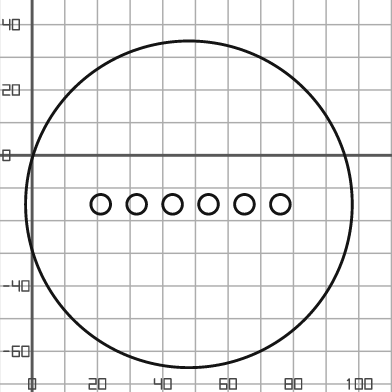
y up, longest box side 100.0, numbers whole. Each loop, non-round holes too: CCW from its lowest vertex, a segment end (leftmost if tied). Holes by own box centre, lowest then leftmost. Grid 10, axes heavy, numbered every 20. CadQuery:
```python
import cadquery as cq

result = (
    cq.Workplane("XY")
    .moveTo(48.0, -15.0)
    .circle(50.0)
    .moveTo(21.0, -15.0)
    .circle(3.0)
    .moveTo(32.0, -15.0)
    .circle(3.0)
    .moveTo(43.0, -15.0)
    .circle(3.0)
    .moveTo(54.0, -15.0)
    .circle(3.0)
    .moveTo(65.0, -15.0)
    .circle(3.0)
    .moveTo(76.0, -15.0)
    .circle(3.0)
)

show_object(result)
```